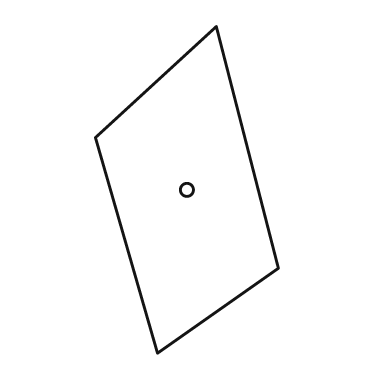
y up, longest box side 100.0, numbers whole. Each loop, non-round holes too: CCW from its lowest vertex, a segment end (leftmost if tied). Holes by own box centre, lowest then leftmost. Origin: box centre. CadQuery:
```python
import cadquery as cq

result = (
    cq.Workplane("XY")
    .moveTo(-9.0, -50.0)
    .lineTo(28.0, -24.0)
    .lineTo(9.0, 50.0)
    .lineTo(-28.0, 16.0)
    .close()
    .moveTo(0.0, 0.0)
    .circle(2.0)
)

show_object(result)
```